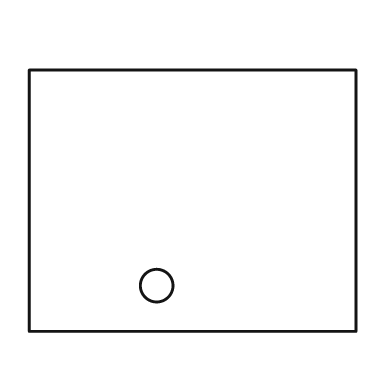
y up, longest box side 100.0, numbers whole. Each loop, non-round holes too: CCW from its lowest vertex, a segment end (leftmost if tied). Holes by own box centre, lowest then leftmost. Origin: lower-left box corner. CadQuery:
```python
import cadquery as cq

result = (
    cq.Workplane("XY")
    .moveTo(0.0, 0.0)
    .lineTo(100.0, 0.0)
    .lineTo(100.0, 80.0)
    .lineTo(0.0, 80.0)
    .close()
    .moveTo(39.0, 14.0)
    .circle(5.0)
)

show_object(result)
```